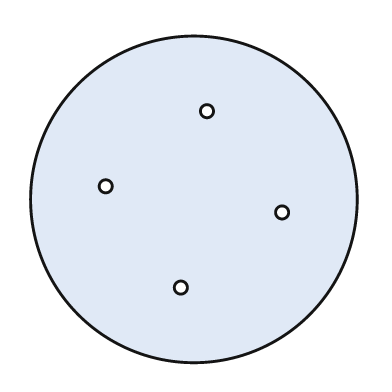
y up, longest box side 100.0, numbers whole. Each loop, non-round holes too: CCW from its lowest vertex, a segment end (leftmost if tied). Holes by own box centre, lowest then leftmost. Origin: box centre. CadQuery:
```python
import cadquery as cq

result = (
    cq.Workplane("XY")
    .moveTo(0.0, 0.0)
    .circle(50.0)
    .moveTo(-4.0, -27.0)
    .circle(2.0)
    .moveTo(27.0, -4.0)
    .circle(2.0)
    .moveTo(-27.0, 4.0)
    .circle(2.0)
    .moveTo(4.0, 27.0)
    .circle(2.0)
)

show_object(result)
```